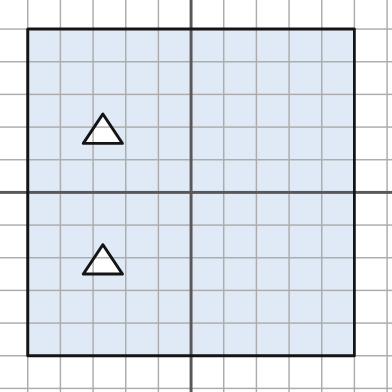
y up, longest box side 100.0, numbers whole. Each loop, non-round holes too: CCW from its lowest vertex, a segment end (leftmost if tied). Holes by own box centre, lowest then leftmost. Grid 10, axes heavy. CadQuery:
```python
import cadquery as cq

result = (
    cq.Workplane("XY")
    .moveTo(-50.0, -50.0)
    .lineTo(50.0, -50.0)
    .lineTo(50.0, 50.0)
    .lineTo(-50.0, 50.0)
    .close()
    .moveTo(-33.0, -25.0)
    .lineTo(-21.0, -25.0)
    .lineTo(-27.0, -16.0)
    .close()
    .moveTo(-33.0, 15.0)
    .lineTo(-21.0, 15.0)
    .lineTo(-27.0, 24.0)
    .close()
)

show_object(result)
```